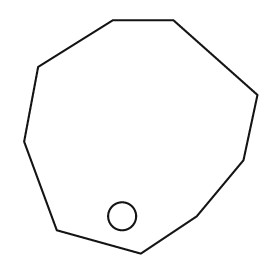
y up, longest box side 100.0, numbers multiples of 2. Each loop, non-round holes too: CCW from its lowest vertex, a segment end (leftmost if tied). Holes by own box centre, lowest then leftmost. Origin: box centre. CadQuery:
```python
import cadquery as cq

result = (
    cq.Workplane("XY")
    .moveTo(0.0, -50.0)
    .lineTo(24.0, -34.0)
    .lineTo(44.0, -10.0)
    .lineTo(50.0, 18.0)
    .lineTo(14.0, 50.0)
    .lineTo(-12.0, 50.0)
    .lineTo(-44.0, 30.0)
    .lineTo(-50.0, -2.0)
    .lineTo(-36.0, -40.0)
    .close()
    .moveTo(-8.0, -34.0)
    .circle(6.0)
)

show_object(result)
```